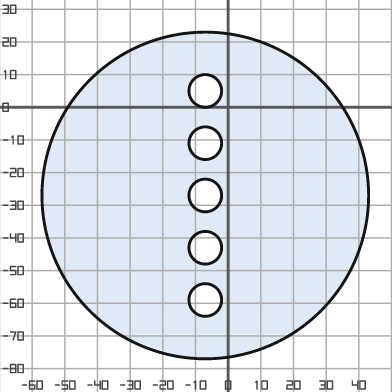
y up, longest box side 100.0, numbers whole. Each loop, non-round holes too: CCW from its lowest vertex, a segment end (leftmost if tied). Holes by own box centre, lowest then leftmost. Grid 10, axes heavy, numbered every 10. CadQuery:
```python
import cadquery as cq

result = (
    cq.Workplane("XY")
    .moveTo(-7.0, -27.0)
    .circle(50.0)
    .moveTo(-7.0, -59.0)
    .circle(5.0)
    .moveTo(-7.0, -43.0)
    .circle(5.0)
    .moveTo(-7.0, -27.0)
    .circle(5.0)
    .moveTo(-7.0, -11.0)
    .circle(5.0)
    .moveTo(-7.0, 5.0)
    .circle(5.0)
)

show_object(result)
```